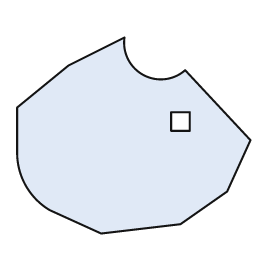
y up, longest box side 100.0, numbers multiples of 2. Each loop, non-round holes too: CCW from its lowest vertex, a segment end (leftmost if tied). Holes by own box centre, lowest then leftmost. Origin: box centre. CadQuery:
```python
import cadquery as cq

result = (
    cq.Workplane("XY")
    .moveTo(-14.0, -42.0)
    .lineTo(20.0, -38.0)
    .lineTo(40.0, -24.0)
    .lineTo(50.0, -2.0)
    .lineTo(22.0, 28.0)
    .threePointArc((4.0, 26.0), (-4.0, 42.0))
    .lineTo(-28.0, 30.0)
    .lineTo(-50.0, 12.0)
    .lineTo(-50.0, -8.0)
    .threePointArc((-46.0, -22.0), (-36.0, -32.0))
    .close()
    .moveTo(16.0, 2.0)
    .lineTo(24.0, 2.0)
    .lineTo(24.0, 10.0)
    .lineTo(16.0, 10.0)
    .close()
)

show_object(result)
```